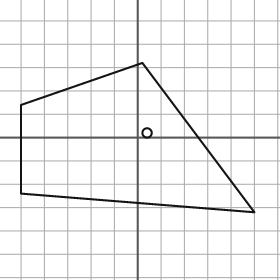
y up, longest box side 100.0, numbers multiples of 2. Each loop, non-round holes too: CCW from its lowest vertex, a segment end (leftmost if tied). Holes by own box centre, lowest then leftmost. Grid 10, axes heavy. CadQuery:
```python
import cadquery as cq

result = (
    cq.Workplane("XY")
    .moveTo(50.0, -32.0)
    .lineTo(2.0, 32.0)
    .lineTo(-50.0, 14.0)
    .lineTo(-50.0, -24.0)
    .close()
    .moveTo(4.0, 2.0)
    .circle(2.0)
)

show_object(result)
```